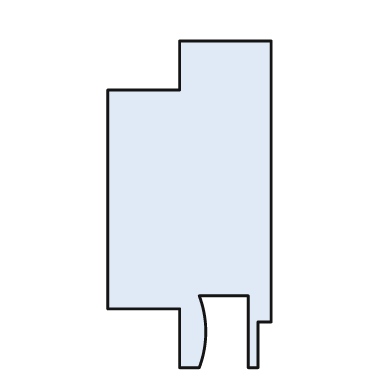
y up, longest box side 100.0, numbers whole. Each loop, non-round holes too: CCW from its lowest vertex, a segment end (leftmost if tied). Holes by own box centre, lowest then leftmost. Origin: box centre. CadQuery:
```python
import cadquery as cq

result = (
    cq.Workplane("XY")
    .moveTo(-3.0, -50.0)
    .lineTo(3.0, -50.0)
    .threePointArc((5.0, -39.0), (3.0, -28.0))
    .lineTo(18.0, -28.0)
    .lineTo(18.0, -50.0)
    .lineTo(21.0, -50.0)
    .lineTo(21.0, -36.0)
    .lineTo(25.0, -36.0)
    .lineTo(25.0, 50.0)
    .lineTo(-3.0, 50.0)
    .lineTo(-3.0, 35.0)
    .lineTo(-25.0, 35.0)
    .lineTo(-25.0, -32.0)
    .lineTo(-3.0, -32.0)
    .close()
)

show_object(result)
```